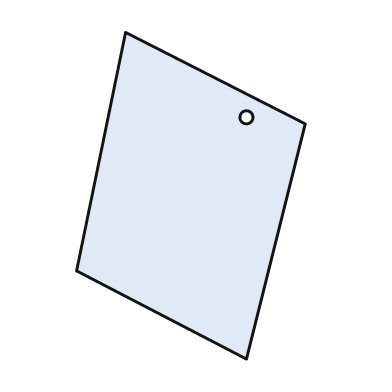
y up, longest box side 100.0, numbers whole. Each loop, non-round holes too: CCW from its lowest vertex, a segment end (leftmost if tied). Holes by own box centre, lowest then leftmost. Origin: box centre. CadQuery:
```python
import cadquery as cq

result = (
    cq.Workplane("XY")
    .moveTo(17.0, -50.0)
    .lineTo(35.0, 22.0)
    .lineTo(-20.0, 50.0)
    .lineTo(-35.0, -23.0)
    .close()
    .moveTo(17.0, 24.0)
    .circle(2.0)
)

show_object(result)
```